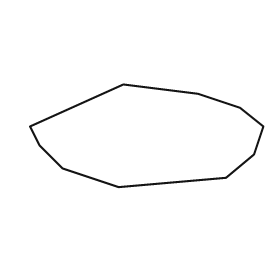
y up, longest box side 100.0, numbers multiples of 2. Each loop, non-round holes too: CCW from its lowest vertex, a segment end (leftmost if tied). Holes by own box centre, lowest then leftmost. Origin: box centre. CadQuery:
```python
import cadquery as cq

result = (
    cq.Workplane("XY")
    .moveTo(-12.0, -22.0)
    .lineTo(34.0, -18.0)
    .lineTo(46.0, -8.0)
    .lineTo(50.0, 4.0)
    .lineTo(40.0, 12.0)
    .lineTo(22.0, 18.0)
    .lineTo(-10.0, 22.0)
    .lineTo(-50.0, 4.0)
    .lineTo(-46.0, -4.0)
    .lineTo(-36.0, -14.0)
    .close()
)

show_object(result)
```